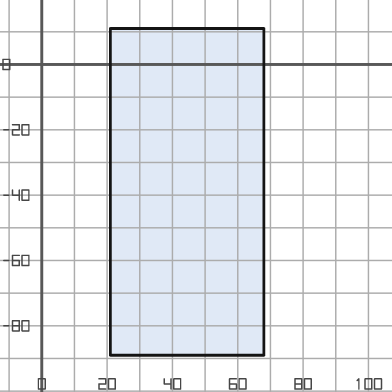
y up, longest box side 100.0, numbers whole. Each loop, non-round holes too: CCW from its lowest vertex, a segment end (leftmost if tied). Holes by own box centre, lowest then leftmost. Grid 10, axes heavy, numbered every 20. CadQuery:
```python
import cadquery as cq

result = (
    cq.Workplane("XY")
    .moveTo(21.0, -89.0)
    .lineTo(68.0, -89.0)
    .lineTo(68.0, 11.0)
    .lineTo(21.0, 11.0)
    .close()
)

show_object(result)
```